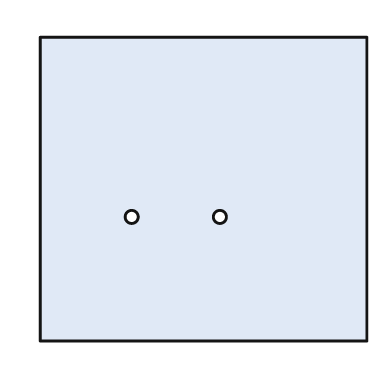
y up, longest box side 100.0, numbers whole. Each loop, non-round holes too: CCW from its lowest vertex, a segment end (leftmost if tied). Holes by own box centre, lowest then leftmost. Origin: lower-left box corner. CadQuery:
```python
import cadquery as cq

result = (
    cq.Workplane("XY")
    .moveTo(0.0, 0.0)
    .lineTo(100.0, 0.0)
    .lineTo(100.0, 93.0)
    .lineTo(0.0, 93.0)
    .close()
    .moveTo(28.0, 38.0)
    .circle(2.0)
    .moveTo(55.0, 38.0)
    .circle(2.0)
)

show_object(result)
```